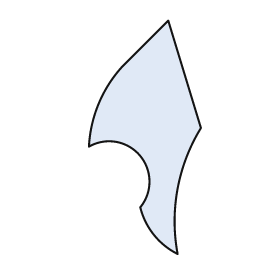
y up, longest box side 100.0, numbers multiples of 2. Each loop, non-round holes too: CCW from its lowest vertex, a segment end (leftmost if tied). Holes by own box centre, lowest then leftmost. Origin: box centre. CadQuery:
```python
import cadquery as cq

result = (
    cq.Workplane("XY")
    .moveTo(14.0, -50.0)
    .threePointArc((14.0, -22.0), (24.0, 4.0))
    .lineTo(10.0, 50.0)
    .lineTo(-10.0, 30.0)
    .threePointArc((-20.0, 14.0), (-24.0, -4.0))
    .threePointArc((-2.0, -8.0), (-2.0, -30.0))
    .threePointArc((4.0, -42.0), (14.0, -50.0))
    .close()
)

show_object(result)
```